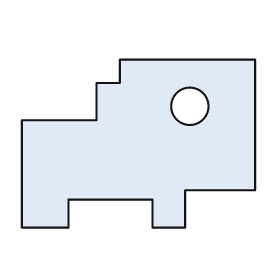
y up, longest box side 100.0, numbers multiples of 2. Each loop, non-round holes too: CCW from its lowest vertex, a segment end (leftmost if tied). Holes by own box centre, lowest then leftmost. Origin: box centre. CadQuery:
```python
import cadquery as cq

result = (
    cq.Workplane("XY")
    .moveTo(-50.0, -36.0)
    .lineTo(-30.0, -36.0)
    .lineTo(-30.0, -24.0)
    .lineTo(6.0, -24.0)
    .lineTo(6.0, -36.0)
    .lineTo(20.0, -36.0)
    .lineTo(20.0, -20.0)
    .lineTo(50.0, -20.0)
    .lineTo(50.0, 36.0)
    .lineTo(-8.0, 36.0)
    .lineTo(-8.0, 26.0)
    .lineTo(-18.0, 26.0)
    .lineTo(-18.0, 10.0)
    .lineTo(-50.0, 10.0)
    .close()
    .moveTo(22.0, 16.0)
    .circle(8.0)
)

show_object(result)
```